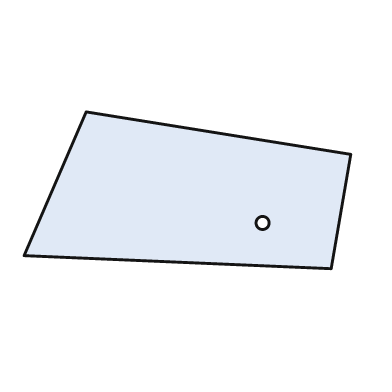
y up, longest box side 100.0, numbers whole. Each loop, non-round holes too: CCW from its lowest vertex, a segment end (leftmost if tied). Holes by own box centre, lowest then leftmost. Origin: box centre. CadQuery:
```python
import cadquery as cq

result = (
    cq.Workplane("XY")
    .moveTo(44.0, -24.0)
    .lineTo(50.0, 11.0)
    .lineTo(-31.0, 24.0)
    .lineTo(-50.0, -20.0)
    .close()
    .moveTo(23.0, -10.0)
    .circle(2.0)
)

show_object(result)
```